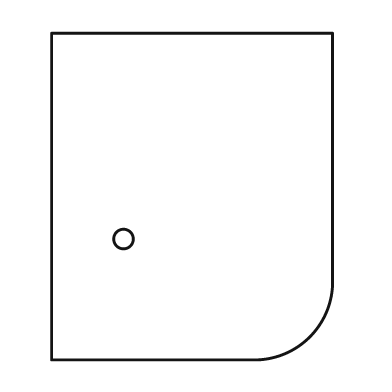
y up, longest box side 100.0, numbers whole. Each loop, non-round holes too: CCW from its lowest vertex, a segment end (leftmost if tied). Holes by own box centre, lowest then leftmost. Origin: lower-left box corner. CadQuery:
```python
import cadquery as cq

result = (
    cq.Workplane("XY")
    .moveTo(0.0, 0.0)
    .lineTo(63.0, 0.0)
    .threePointArc((79.0, 7.0), (86.0, 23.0))
    .lineTo(86.0, 100.0)
    .lineTo(0.0, 100.0)
    .close()
    .moveTo(22.0, 37.0)
    .circle(3.0)
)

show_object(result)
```